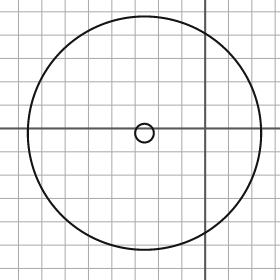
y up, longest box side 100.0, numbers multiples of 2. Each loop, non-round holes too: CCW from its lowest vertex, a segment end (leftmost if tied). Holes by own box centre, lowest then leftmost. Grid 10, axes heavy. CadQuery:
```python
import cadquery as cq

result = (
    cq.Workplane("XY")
    .moveTo(-26.0, -2.0)
    .circle(50.0)
    .moveTo(-26.0, -2.0)
    .circle(4.0)
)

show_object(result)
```